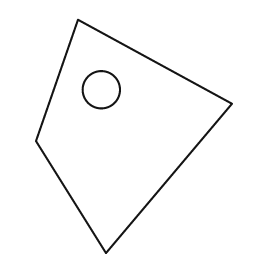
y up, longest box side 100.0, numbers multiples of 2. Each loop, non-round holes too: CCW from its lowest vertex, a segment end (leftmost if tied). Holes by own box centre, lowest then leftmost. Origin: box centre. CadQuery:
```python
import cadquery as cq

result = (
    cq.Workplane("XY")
    .moveTo(-12.0, -50.0)
    .lineTo(42.0, 14.0)
    .lineTo(-24.0, 50.0)
    .lineTo(-42.0, -2.0)
    .close()
    .moveTo(-14.0, 20.0)
    .circle(8.0)
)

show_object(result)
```